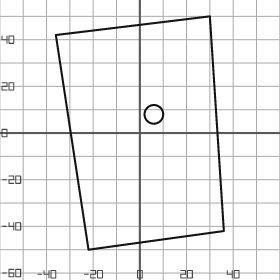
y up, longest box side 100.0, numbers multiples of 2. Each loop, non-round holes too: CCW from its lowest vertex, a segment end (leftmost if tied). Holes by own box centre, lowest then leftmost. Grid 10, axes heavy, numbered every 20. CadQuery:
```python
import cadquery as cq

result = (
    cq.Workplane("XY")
    .moveTo(-22.0, -50.0)
    .lineTo(36.0, -42.0)
    .lineTo(30.0, 50.0)
    .lineTo(-36.0, 42.0)
    .close()
    .moveTo(6.0, 8.0)
    .circle(4.0)
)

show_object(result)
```